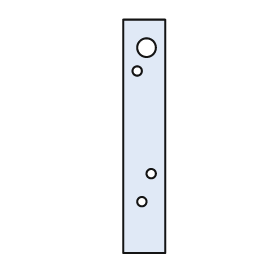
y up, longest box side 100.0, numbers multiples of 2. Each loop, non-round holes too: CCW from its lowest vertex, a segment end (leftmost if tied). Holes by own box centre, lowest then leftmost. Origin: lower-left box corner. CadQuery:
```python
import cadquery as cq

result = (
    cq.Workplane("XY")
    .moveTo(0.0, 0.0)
    .lineTo(18.0, 0.0)
    .lineTo(18.0, 100.0)
    .lineTo(0.0, 100.0)
    .close()
    .moveTo(8.0, 22.0)
    .circle(2.0)
    .moveTo(12.0, 34.0)
    .circle(2.0)
    .moveTo(6.0, 78.0)
    .circle(2.0)
    .moveTo(10.0, 88.0)
    .circle(4.0)
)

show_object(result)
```